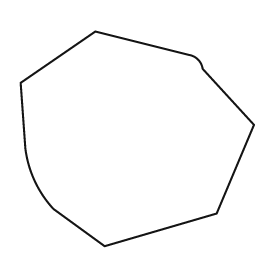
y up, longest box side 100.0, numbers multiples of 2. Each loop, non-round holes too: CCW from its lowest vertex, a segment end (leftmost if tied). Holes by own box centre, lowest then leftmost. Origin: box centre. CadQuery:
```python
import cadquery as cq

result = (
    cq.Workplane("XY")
    .moveTo(-14.0, -46.0)
    .lineTo(34.0, -32.0)
    .lineTo(50.0, 6.0)
    .lineTo(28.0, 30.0)
    .threePointArc((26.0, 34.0), (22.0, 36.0))
    .lineTo(-18.0, 46.0)
    .lineTo(-50.0, 24.0)
    .lineTo(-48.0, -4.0)
    .threePointArc((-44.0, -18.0), (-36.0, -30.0))
    .close()
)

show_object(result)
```